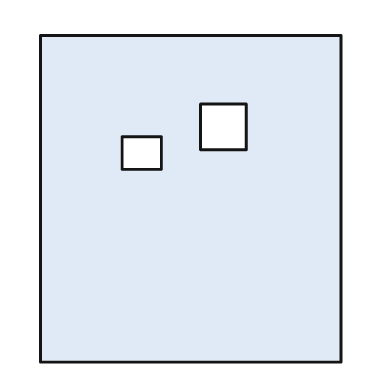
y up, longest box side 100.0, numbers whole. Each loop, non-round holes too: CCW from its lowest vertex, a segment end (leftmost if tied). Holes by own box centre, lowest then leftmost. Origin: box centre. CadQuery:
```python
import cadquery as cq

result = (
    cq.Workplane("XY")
    .moveTo(-46.0, -50.0)
    .lineTo(46.0, -50.0)
    .lineTo(46.0, 50.0)
    .lineTo(-46.0, 50.0)
    .close()
    .moveTo(-21.0, 9.0)
    .lineTo(-9.0, 9.0)
    .lineTo(-9.0, 19.0)
    .lineTo(-21.0, 19.0)
    .close()
    .moveTo(3.0, 15.0)
    .lineTo(17.0, 15.0)
    .lineTo(17.0, 29.0)
    .lineTo(3.0, 29.0)
    .close()
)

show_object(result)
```